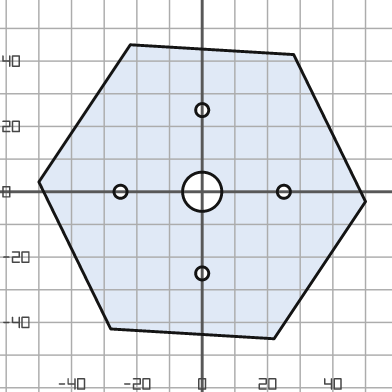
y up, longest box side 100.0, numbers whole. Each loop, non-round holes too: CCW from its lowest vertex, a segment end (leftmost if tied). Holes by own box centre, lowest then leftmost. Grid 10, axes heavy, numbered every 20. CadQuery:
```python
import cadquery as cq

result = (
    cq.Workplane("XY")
    .moveTo(22.0, -45.0)
    .lineTo(50.0, -3.0)
    .lineTo(28.0, 42.0)
    .lineTo(-22.0, 45.0)
    .lineTo(-50.0, 3.0)
    .lineTo(-28.0, -42.0)
    .close()
    .moveTo(0.0, -25.0)
    .circle(2.0)
    .moveTo(-25.0, 0.0)
    .circle(2.0)
    .moveTo(0.0, 0.0)
    .circle(6.0)
    .moveTo(25.0, 0.0)
    .circle(2.0)
    .moveTo(0.0, 25.0)
    .circle(2.0)
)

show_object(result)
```